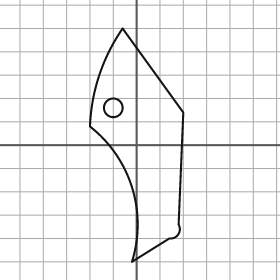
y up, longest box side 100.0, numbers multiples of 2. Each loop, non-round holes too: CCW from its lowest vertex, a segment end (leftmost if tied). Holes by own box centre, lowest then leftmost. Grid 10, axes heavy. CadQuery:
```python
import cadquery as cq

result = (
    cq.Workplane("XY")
    .moveTo(-2.0, -50.0)
    .lineTo(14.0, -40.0)
    .threePointArc((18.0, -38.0), (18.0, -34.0))
    .lineTo(20.0, 14.0)
    .lineTo(-6.0, 50.0)
    .threePointArc((-16.0, 30.0), (-20.0, 8.0))
    .threePointArc((-2.0, -18.0), (-2.0, -50.0))
    .close()
    .moveTo(-10.0, 16.0)
    .circle(4.0)
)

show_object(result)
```